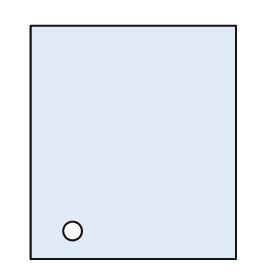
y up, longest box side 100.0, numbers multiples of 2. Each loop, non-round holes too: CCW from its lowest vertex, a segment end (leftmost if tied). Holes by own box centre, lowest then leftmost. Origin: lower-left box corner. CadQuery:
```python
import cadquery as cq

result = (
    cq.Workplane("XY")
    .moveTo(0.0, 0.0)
    .lineTo(88.0, 0.0)
    .lineTo(88.0, 100.0)
    .lineTo(0.0, 100.0)
    .close()
    .moveTo(18.0, 12.0)
    .circle(4.0)
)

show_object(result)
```